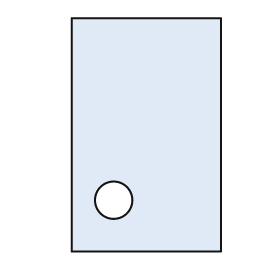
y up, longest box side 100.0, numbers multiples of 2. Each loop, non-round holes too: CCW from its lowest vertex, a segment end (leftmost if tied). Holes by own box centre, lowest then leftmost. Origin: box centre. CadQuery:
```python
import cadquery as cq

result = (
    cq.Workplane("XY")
    .moveTo(-32.0, -50.0)
    .lineTo(32.0, -50.0)
    .lineTo(32.0, 50.0)
    .lineTo(-32.0, 50.0)
    .close()
    .moveTo(-14.0, -28.0)
    .circle(8.0)
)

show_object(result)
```